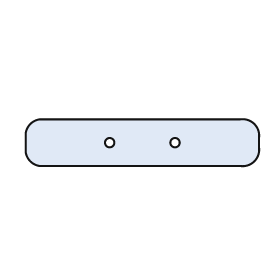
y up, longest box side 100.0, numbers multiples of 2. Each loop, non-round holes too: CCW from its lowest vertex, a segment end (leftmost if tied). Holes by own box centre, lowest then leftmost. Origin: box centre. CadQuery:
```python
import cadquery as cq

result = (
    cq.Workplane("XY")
    .moveTo(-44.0, -10.0)
    .lineTo(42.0, -10.0)
    .threePointArc((48.0, -8.0), (50.0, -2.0))
    .lineTo(50.0, 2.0)
    .threePointArc((48.0, 8.0), (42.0, 10.0))
    .lineTo(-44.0, 10.0)
    .threePointArc((-48.0, 8.0), (-50.0, 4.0))
    .lineTo(-50.0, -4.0)
    .threePointArc((-48.0, -8.0), (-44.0, -10.0))
    .close()
    .moveTo(-14.0, 0.0)
    .circle(2.0)
    .moveTo(14.0, 0.0)
    .circle(2.0)
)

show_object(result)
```